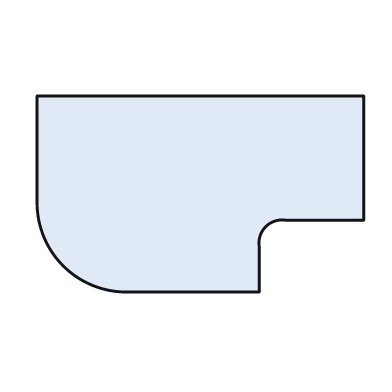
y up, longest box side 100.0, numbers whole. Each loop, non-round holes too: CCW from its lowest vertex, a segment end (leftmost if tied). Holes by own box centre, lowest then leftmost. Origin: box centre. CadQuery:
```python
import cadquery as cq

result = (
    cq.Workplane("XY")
    .moveTo(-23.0, -30.0)
    .lineTo(18.0, -30.0)
    .lineTo(18.0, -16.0)
    .threePointArc((20.0, -10.0), (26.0, -8.0))
    .lineTo(50.0, -8.0)
    .lineTo(50.0, 30.0)
    .lineTo(-50.0, 30.0)
    .lineTo(-50.0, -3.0)
    .threePointArc((-42.0, -22.0), (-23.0, -30.0))
    .close()
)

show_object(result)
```